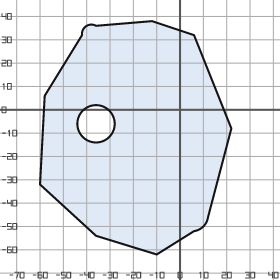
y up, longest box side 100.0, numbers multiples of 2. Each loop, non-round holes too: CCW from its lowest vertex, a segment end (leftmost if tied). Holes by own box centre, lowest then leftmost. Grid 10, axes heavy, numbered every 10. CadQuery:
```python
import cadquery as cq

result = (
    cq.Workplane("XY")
    .moveTo(-10.0, -62.0)
    .lineTo(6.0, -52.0)
    .threePointArc((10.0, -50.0), (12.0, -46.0))
    .lineTo(22.0, -8.0)
    .lineTo(6.0, 32.0)
    .lineTo(-12.0, 38.0)
    .lineTo(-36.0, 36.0)
    .threePointArc((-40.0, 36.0), (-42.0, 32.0))
    .lineTo(-58.0, 6.0)
    .lineTo(-60.0, -32.0)
    .lineTo(-36.0, -54.0)
    .close()
    .moveTo(-36.0, -6.0)
    .circle(8.0)
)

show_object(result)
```